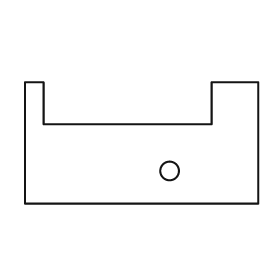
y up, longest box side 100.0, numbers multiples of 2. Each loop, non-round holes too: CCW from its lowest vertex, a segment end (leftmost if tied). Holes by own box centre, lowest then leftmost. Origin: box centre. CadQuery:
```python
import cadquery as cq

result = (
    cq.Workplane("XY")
    .moveTo(-50.0, -26.0)
    .lineTo(50.0, -26.0)
    .lineTo(50.0, 26.0)
    .lineTo(30.0, 26.0)
    .lineTo(30.0, 8.0)
    .lineTo(-42.0, 8.0)
    .lineTo(-42.0, 26.0)
    .lineTo(-50.0, 26.0)
    .close()
    .moveTo(12.0, -12.0)
    .circle(4.0)
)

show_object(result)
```